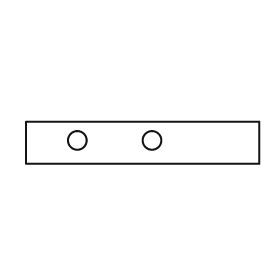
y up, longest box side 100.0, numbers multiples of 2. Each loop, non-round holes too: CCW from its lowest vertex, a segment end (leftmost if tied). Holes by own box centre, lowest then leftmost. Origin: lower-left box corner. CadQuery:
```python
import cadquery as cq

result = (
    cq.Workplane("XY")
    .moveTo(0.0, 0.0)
    .lineTo(100.0, 0.0)
    .lineTo(100.0, 18.0)
    .lineTo(0.0, 18.0)
    .close()
    .moveTo(22.0, 10.0)
    .circle(4.0)
    .moveTo(54.0, 10.0)
    .circle(4.0)
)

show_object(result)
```